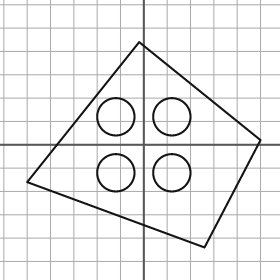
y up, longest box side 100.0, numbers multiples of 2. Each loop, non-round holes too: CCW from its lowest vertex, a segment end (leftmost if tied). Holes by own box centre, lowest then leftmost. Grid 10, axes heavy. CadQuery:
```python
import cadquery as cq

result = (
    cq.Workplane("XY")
    .moveTo(26.0, -44.0)
    .lineTo(50.0, 2.0)
    .lineTo(-2.0, 44.0)
    .lineTo(-50.0, -16.0)
    .close()
    .moveTo(-12.0, -12.0)
    .circle(8.0)
    .moveTo(12.0, -12.0)
    .circle(8.0)
    .moveTo(-12.0, 12.0)
    .circle(8.0)
    .moveTo(12.0, 12.0)
    .circle(8.0)
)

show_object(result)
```